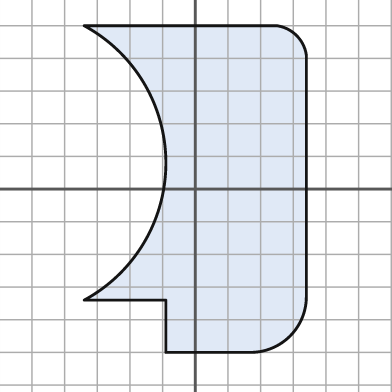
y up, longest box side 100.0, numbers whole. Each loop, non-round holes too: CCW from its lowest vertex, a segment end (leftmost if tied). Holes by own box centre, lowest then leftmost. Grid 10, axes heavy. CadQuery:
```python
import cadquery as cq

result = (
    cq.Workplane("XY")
    .moveTo(-9.0, -50.0)
    .lineTo(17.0, -50.0)
    .threePointArc((29.0, -45.0), (34.0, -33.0))
    .lineTo(34.0, 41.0)
    .threePointArc((31.0, 47.0), (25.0, 50.0))
    .lineTo(-34.0, 50.0)
    .threePointArc((-9.0, 8.0), (-34.0, -34.0))
    .lineTo(-9.0, -34.0)
    .close()
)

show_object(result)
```